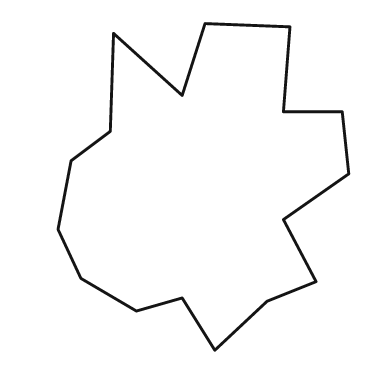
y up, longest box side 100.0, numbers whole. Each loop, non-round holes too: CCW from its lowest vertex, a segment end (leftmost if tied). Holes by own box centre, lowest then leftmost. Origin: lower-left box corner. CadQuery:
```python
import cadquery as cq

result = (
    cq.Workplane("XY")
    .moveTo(48.0, 0.0)
    .lineTo(64.0, 15.0)
    .lineTo(79.0, 21.0)
    .lineTo(69.0, 40.0)
    .lineTo(89.0, 54.0)
    .lineTo(87.0, 73.0)
    .lineTo(69.0, 73.0)
    .lineTo(71.0, 99.0)
    .lineTo(45.0, 100.0)
    .lineTo(38.0, 78.0)
    .lineTo(17.0, 97.0)
    .lineTo(16.0, 67.0)
    .lineTo(4.0, 58.0)
    .lineTo(0.0, 37.0)
    .lineTo(7.0, 22.0)
    .lineTo(24.0, 12.0)
    .lineTo(38.0, 16.0)
    .close()
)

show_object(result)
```